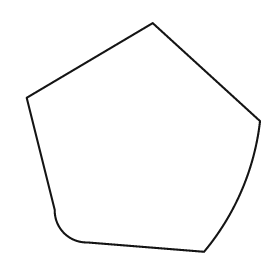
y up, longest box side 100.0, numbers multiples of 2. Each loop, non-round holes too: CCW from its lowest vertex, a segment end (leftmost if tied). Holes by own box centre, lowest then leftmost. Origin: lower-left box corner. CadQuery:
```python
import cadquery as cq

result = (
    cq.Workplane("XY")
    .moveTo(76.0, 0.0)
    .threePointArc((92.0, 26.0), (100.0, 56.0))
    .lineTo(54.0, 98.0)
    .lineTo(0.0, 66.0)
    .lineTo(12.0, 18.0)
    .threePointArc((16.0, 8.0), (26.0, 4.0))
    .close()
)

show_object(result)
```